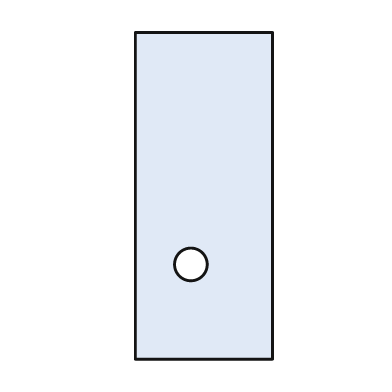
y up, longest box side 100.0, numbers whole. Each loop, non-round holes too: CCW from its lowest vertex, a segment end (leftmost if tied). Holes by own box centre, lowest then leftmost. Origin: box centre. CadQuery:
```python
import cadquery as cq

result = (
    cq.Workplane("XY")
    .moveTo(-21.0, -50.0)
    .lineTo(21.0, -50.0)
    .lineTo(21.0, 50.0)
    .lineTo(-21.0, 50.0)
    .close()
    .moveTo(-4.0, -21.0)
    .circle(5.0)
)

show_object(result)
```